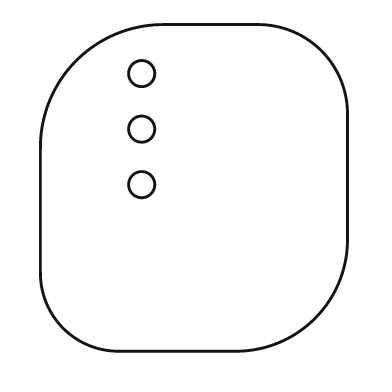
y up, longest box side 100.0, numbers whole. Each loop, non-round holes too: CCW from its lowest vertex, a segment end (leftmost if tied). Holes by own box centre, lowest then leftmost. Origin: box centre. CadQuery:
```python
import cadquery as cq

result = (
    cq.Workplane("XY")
    .moveTo(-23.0, -50.0)
    .lineTo(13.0, -50.0)
    .threePointArc((37.0, -40.0), (47.0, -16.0))
    .lineTo(47.0, 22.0)
    .threePointArc((39.0, 42.0), (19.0, 50.0))
    .lineTo(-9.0, 50.0)
    .threePointArc((-36.0, 39.0), (-47.0, 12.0))
    .lineTo(-47.0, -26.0)
    .threePointArc((-40.0, -43.0), (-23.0, -50.0))
    .close()
    .moveTo(-16.0, 1.0)
    .circle(4.0)
    .moveTo(-16.0, 18.0)
    .circle(4.0)
    .moveTo(-16.0, 35.0)
    .circle(4.0)
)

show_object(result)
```